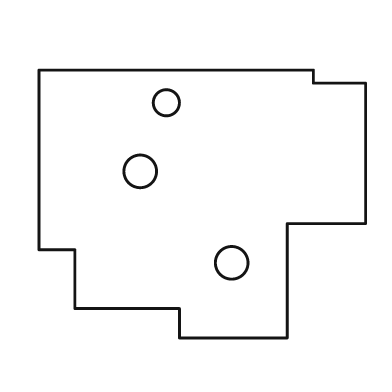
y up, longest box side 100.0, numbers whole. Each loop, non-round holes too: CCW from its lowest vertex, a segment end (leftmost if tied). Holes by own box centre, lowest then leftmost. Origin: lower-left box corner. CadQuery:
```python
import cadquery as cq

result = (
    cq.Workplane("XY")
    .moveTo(43.0, 0.0)
    .lineTo(76.0, 0.0)
    .lineTo(76.0, 35.0)
    .lineTo(100.0, 35.0)
    .lineTo(100.0, 78.0)
    .lineTo(84.0, 78.0)
    .lineTo(84.0, 82.0)
    .lineTo(0.0, 82.0)
    .lineTo(0.0, 27.0)
    .lineTo(11.0, 27.0)
    .lineTo(11.0, 9.0)
    .lineTo(43.0, 9.0)
    .close()
    .moveTo(59.0, 23.0)
    .circle(5.0)
    .moveTo(31.0, 51.0)
    .circle(5.0)
    .moveTo(39.0, 72.0)
    .circle(4.0)
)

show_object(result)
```